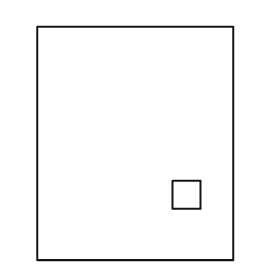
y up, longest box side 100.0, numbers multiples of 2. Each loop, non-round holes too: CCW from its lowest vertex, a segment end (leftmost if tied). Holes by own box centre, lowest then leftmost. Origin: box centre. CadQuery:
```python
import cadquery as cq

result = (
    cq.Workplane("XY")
    .moveTo(-42.0, -50.0)
    .lineTo(42.0, -50.0)
    .lineTo(42.0, 50.0)
    .lineTo(-42.0, 50.0)
    .close()
    .moveTo(16.0, -28.0)
    .lineTo(28.0, -28.0)
    .lineTo(28.0, -16.0)
    .lineTo(16.0, -16.0)
    .close()
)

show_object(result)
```